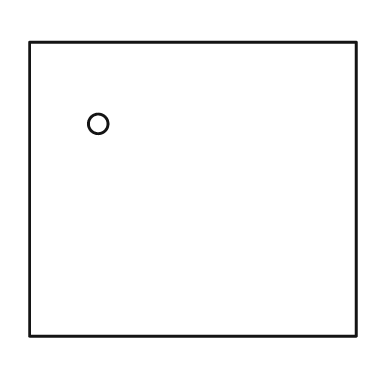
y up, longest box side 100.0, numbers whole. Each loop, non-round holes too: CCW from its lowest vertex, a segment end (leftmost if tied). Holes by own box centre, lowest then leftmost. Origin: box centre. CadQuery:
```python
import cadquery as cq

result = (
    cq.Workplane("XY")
    .moveTo(-50.0, -45.0)
    .lineTo(50.0, -45.0)
    .lineTo(50.0, 45.0)
    .lineTo(-50.0, 45.0)
    .close()
    .moveTo(-29.0, 20.0)
    .circle(3.0)
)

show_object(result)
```